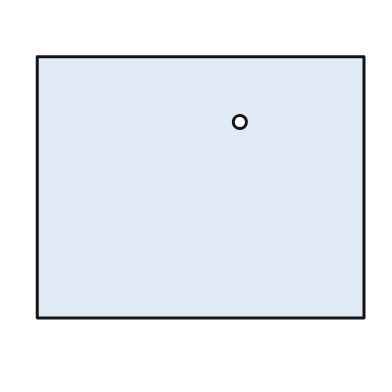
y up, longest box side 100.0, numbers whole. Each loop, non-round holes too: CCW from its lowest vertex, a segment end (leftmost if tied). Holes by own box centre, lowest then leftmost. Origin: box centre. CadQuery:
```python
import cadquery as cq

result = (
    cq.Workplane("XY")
    .moveTo(-50.0, -40.0)
    .lineTo(50.0, -40.0)
    .lineTo(50.0, 40.0)
    .lineTo(-50.0, 40.0)
    .close()
    .moveTo(12.0, 20.0)
    .circle(2.0)
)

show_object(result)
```